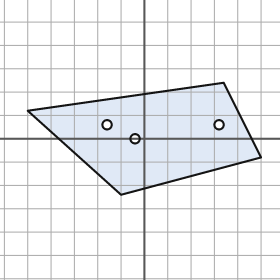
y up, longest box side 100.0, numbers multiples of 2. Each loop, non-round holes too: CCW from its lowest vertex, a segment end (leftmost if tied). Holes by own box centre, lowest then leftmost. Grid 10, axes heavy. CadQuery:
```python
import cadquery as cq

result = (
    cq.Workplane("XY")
    .moveTo(-10.0, -24.0)
    .lineTo(50.0, -8.0)
    .lineTo(34.0, 24.0)
    .lineTo(-50.0, 12.0)
    .close()
    .moveTo(-4.0, 0.0)
    .circle(2.0)
    .moveTo(-16.0, 6.0)
    .circle(2.0)
    .moveTo(32.0, 6.0)
    .circle(2.0)
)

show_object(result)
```